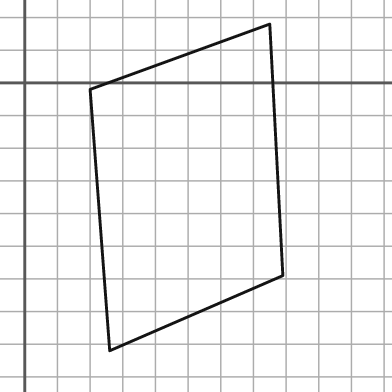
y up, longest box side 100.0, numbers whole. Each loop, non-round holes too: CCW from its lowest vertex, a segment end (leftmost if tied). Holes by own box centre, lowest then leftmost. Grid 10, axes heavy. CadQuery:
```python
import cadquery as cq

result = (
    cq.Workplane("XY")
    .moveTo(26.0, -82.0)
    .lineTo(79.0, -59.0)
    .lineTo(75.0, 18.0)
    .lineTo(20.0, -2.0)
    .close()
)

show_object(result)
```